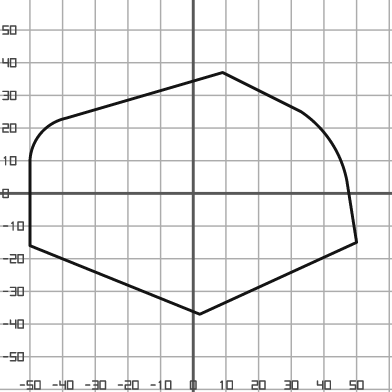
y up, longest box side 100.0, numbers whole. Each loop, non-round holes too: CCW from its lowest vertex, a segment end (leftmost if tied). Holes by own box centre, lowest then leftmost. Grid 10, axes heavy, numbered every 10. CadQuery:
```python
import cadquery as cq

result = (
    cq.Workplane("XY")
    .moveTo(2.0, -37.0)
    .lineTo(50.0, -15.0)
    .lineTo(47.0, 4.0)
    .threePointArc((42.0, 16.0), (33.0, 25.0))
    .lineTo(9.0, 37.0)
    .lineTo(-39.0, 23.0)
    .threePointArc((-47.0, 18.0), (-50.0, 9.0))
    .lineTo(-50.0, -16.0)
    .close()
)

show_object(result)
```